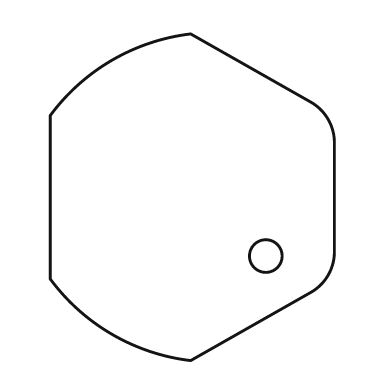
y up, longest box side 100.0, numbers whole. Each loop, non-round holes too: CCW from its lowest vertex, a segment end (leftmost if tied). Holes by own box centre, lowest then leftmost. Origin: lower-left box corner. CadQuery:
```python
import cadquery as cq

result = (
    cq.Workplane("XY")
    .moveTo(43.0, 0.0)
    .lineTo(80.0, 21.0)
    .threePointArc((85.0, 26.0), (87.0, 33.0))
    .lineTo(87.0, 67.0)
    .threePointArc((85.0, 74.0), (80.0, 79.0))
    .lineTo(43.0, 100.0)
    .threePointArc((19.0, 92.0), (0.0, 75.0))
    .lineTo(0.0, 25.0)
    .threePointArc((19.0, 8.0), (43.0, 0.0))
    .close()
    .moveTo(66.0, 32.0)
    .circle(5.0)
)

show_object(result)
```